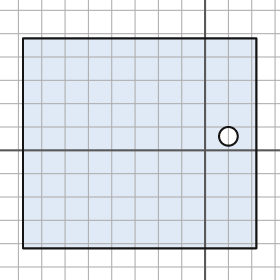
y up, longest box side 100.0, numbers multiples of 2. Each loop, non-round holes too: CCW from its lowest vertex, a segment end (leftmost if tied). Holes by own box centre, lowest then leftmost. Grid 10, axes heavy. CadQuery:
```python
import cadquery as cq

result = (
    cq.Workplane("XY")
    .moveTo(-78.0, -42.0)
    .lineTo(22.0, -42.0)
    .lineTo(22.0, 48.0)
    .lineTo(-78.0, 48.0)
    .close()
    .moveTo(10.0, 6.0)
    .circle(4.0)
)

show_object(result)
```